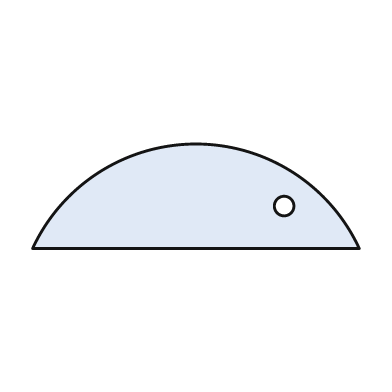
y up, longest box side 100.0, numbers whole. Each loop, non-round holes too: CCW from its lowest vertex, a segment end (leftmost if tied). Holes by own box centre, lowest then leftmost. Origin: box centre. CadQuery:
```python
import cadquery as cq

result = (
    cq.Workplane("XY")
    .moveTo(-50.0, -16.0)
    .lineTo(50.0, -16.0)
    .threePointArc((0.0, 16.0), (-50.0, -16.0))
    .close()
    .moveTo(27.0, -3.0)
    .circle(3.0)
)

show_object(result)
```